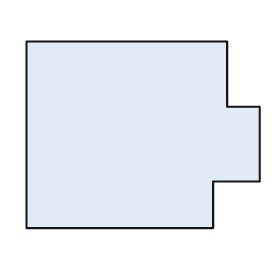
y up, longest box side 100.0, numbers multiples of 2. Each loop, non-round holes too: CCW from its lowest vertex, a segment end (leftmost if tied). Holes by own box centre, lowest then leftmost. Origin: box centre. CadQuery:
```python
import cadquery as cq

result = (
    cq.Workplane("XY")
    .moveTo(-50.0, -40.0)
    .lineTo(30.0, -40.0)
    .lineTo(30.0, -20.0)
    .lineTo(50.0, -20.0)
    .lineTo(50.0, 12.0)
    .lineTo(36.0, 12.0)
    .lineTo(36.0, 40.0)
    .lineTo(-50.0, 40.0)
    .close()
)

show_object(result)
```